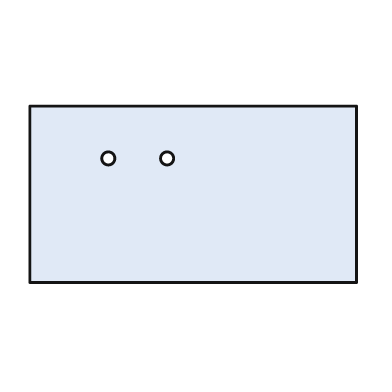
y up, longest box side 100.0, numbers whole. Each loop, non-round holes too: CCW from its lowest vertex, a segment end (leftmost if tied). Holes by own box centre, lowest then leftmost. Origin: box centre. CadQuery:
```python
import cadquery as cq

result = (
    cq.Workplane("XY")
    .moveTo(-50.0, -27.0)
    .lineTo(50.0, -27.0)
    .lineTo(50.0, 27.0)
    .lineTo(-50.0, 27.0)
    .close()
    .moveTo(-26.0, 11.0)
    .circle(2.0)
    .moveTo(-8.0, 11.0)
    .circle(2.0)
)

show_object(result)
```